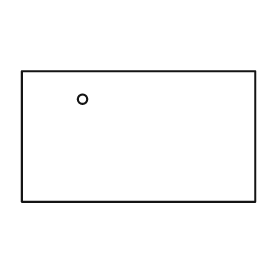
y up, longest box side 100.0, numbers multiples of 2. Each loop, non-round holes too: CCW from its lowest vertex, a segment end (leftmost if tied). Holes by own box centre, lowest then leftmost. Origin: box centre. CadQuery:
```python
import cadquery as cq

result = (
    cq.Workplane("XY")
    .moveTo(-50.0, -28.0)
    .lineTo(50.0, -28.0)
    .lineTo(50.0, 28.0)
    .lineTo(-50.0, 28.0)
    .close()
    .moveTo(-24.0, 16.0)
    .circle(2.0)
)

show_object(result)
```